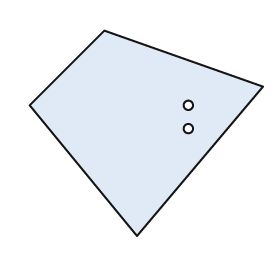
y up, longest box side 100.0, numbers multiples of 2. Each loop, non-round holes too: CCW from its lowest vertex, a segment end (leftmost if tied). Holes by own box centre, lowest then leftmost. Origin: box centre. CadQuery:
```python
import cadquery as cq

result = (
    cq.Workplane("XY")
    .moveTo(-4.0, -44.0)
    .lineTo(50.0, 20.0)
    .lineTo(-18.0, 44.0)
    .lineTo(-50.0, 12.0)
    .close()
    .moveTo(18.0, 2.0)
    .circle(2.0)
    .moveTo(18.0, 12.0)
    .circle(2.0)
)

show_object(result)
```